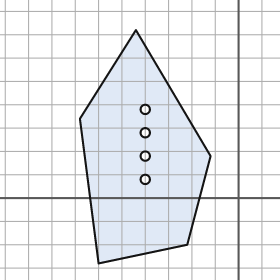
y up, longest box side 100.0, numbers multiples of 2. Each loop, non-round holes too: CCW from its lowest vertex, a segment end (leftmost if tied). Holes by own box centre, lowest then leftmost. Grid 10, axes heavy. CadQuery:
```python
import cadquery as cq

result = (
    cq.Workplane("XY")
    .moveTo(-60.0, -28.0)
    .lineTo(-22.0, -20.0)
    .lineTo(-12.0, 18.0)
    .lineTo(-44.0, 72.0)
    .lineTo(-68.0, 34.0)
    .close()
    .moveTo(-40.0, 8.0)
    .circle(2.0)
    .moveTo(-40.0, 18.0)
    .circle(2.0)
    .moveTo(-40.0, 28.0)
    .circle(2.0)
    .moveTo(-40.0, 38.0)
    .circle(2.0)
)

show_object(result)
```